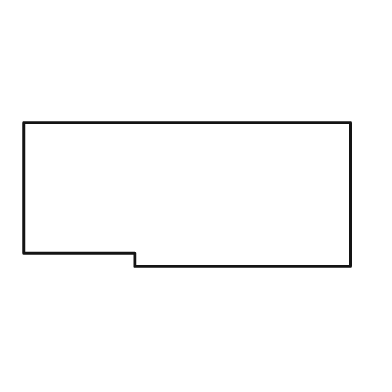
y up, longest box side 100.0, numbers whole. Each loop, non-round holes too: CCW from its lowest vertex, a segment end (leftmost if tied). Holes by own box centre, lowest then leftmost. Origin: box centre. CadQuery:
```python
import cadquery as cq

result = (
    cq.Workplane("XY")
    .moveTo(-16.0, -22.0)
    .lineTo(50.0, -22.0)
    .lineTo(50.0, 22.0)
    .lineTo(-50.0, 22.0)
    .lineTo(-50.0, -18.0)
    .lineTo(-16.0, -18.0)
    .close()
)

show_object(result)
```